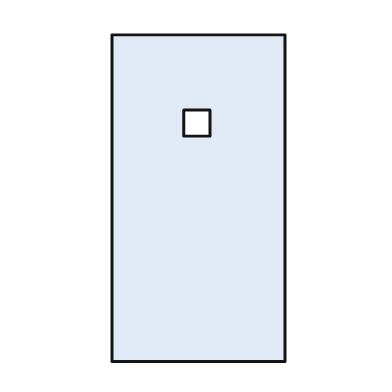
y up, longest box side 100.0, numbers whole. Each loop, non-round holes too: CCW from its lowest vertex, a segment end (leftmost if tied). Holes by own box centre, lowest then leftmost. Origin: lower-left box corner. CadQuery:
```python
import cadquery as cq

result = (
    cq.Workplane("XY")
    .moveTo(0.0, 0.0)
    .lineTo(53.0, 0.0)
    .lineTo(53.0, 100.0)
    .lineTo(0.0, 100.0)
    .close()
    .moveTo(22.0, 69.0)
    .lineTo(30.0, 69.0)
    .lineTo(30.0, 77.0)
    .lineTo(22.0, 77.0)
    .close()
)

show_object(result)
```